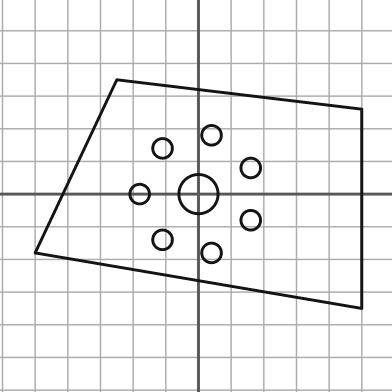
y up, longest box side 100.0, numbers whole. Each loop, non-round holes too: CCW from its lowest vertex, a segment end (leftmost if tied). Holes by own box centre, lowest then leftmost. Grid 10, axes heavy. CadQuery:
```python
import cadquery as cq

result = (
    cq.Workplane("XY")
    .moveTo(50.0, -35.0)
    .lineTo(50.0, 26.0)
    .lineTo(-25.0, 35.0)
    .lineTo(-50.0, -18.0)
    .close()
    .moveTo(4.0, -18.0)
    .circle(3.0)
    .moveTo(-11.0, -14.0)
    .circle(3.0)
    .moveTo(16.0, -8.0)
    .circle(3.0)
    .moveTo(-18.0, 0.0)
    .circle(3.0)
    .moveTo(0.0, 0.0)
    .circle(6.0)
    .moveTo(16.0, 8.0)
    .circle(3.0)
    .moveTo(-11.0, 14.0)
    .circle(3.0)
    .moveTo(4.0, 18.0)
    .circle(3.0)
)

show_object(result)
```